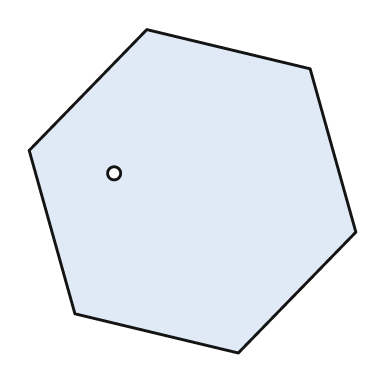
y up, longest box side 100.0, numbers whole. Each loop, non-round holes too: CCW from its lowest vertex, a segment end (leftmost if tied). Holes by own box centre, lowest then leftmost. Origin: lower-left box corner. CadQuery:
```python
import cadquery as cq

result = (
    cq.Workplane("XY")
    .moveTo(64.0, 0.0)
    .lineTo(100.0, 37.0)
    .lineTo(86.0, 87.0)
    .lineTo(36.0, 99.0)
    .lineTo(0.0, 62.0)
    .lineTo(14.0, 12.0)
    .close()
    .moveTo(26.0, 55.0)
    .circle(2.0)
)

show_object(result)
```